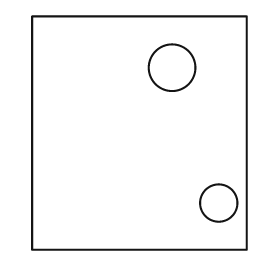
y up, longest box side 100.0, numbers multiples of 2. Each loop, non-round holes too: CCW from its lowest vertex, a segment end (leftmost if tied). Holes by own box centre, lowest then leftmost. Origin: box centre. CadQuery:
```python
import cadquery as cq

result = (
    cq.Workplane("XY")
    .moveTo(-46.0, -50.0)
    .lineTo(46.0, -50.0)
    .lineTo(46.0, 50.0)
    .lineTo(-46.0, 50.0)
    .close()
    .moveTo(34.0, -30.0)
    .circle(8.0)
    .moveTo(14.0, 28.0)
    .circle(10.0)
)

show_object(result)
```